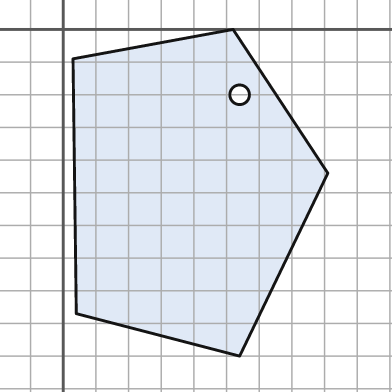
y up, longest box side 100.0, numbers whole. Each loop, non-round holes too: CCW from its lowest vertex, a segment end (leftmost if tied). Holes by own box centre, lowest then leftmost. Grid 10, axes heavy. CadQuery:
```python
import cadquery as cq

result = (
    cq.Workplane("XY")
    .moveTo(54.0, -100.0)
    .lineTo(81.0, -44.0)
    .lineTo(52.0, 0.0)
    .lineTo(3.0, -9.0)
    .lineTo(4.0, -87.0)
    .close()
    .moveTo(54.0, -20.0)
    .circle(3.0)
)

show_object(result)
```